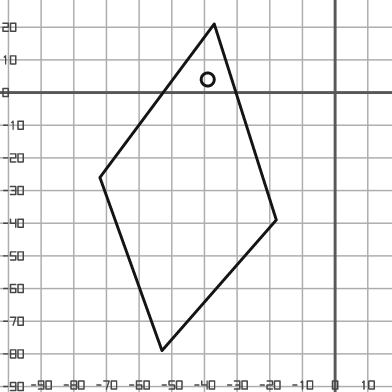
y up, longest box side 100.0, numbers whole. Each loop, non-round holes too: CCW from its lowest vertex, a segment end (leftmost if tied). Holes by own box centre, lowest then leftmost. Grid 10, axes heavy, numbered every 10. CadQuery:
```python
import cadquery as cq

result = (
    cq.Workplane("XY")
    .moveTo(-53.0, -79.0)
    .lineTo(-18.0, -39.0)
    .lineTo(-37.0, 21.0)
    .lineTo(-72.0, -26.0)
    .close()
    .moveTo(-39.0, 4.0)
    .circle(2.0)
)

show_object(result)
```